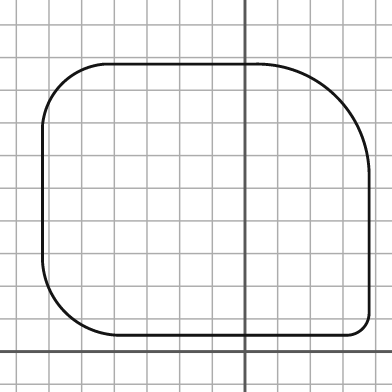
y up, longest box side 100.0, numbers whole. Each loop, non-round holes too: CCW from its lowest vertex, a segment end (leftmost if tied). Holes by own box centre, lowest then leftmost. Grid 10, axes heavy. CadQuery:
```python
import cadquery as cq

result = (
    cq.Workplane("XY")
    .moveTo(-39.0, 5.0)
    .lineTo(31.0, 5.0)
    .threePointArc((36.0, 7.0), (38.0, 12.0))
    .lineTo(38.0, 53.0)
    .threePointArc((28.0, 78.0), (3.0, 88.0))
    .lineTo(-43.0, 88.0)
    .threePointArc((-56.0, 82.0), (-62.0, 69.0))
    .lineTo(-62.0, 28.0)
    .threePointArc((-55.0, 12.0), (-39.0, 5.0))
    .close()
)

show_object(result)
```